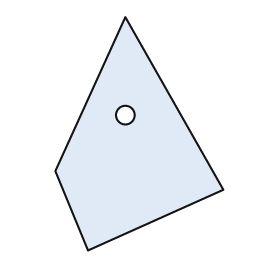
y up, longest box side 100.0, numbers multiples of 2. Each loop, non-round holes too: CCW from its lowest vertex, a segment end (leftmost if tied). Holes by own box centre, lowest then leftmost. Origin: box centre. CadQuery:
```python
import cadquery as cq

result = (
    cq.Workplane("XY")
    .moveTo(-22.0, -50.0)
    .lineTo(36.0, -24.0)
    .lineTo(-6.0, 50.0)
    .lineTo(-36.0, -16.0)
    .close()
    .moveTo(-6.0, 8.0)
    .circle(4.0)
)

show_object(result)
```